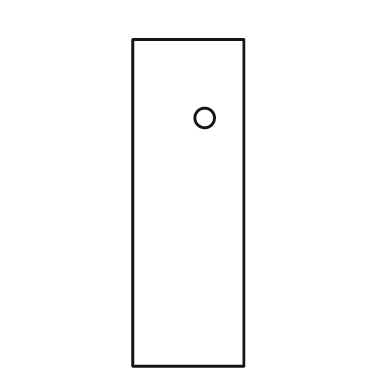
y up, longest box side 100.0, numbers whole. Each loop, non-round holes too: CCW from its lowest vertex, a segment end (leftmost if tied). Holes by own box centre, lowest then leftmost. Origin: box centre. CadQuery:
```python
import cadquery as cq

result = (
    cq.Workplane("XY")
    .moveTo(-17.0, -50.0)
    .lineTo(17.0, -50.0)
    .lineTo(17.0, 50.0)
    .lineTo(-17.0, 50.0)
    .close()
    .moveTo(5.0, 26.0)
    .circle(3.0)
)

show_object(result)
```